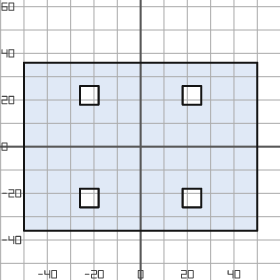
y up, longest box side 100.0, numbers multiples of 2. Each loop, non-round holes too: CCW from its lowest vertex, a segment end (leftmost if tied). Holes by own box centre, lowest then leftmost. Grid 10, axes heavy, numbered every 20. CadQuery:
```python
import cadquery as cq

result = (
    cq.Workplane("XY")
    .moveTo(-50.0, -36.0)
    .lineTo(50.0, -36.0)
    .lineTo(50.0, 36.0)
    .lineTo(-50.0, 36.0)
    .close()
    .moveTo(-26.0, -26.0)
    .lineTo(-18.0, -26.0)
    .lineTo(-18.0, -18.0)
    .lineTo(-26.0, -18.0)
    .close()
    .moveTo(18.0, -26.0)
    .lineTo(26.0, -26.0)
    .lineTo(26.0, -18.0)
    .lineTo(18.0, -18.0)
    .close()
    .moveTo(-26.0, 18.0)
    .lineTo(-18.0, 18.0)
    .lineTo(-18.0, 26.0)
    .lineTo(-26.0, 26.0)
    .close()
    .moveTo(18.0, 18.0)
    .lineTo(26.0, 18.0)
    .lineTo(26.0, 26.0)
    .lineTo(18.0, 26.0)
    .close()
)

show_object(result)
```